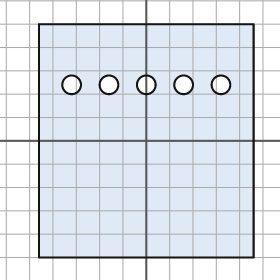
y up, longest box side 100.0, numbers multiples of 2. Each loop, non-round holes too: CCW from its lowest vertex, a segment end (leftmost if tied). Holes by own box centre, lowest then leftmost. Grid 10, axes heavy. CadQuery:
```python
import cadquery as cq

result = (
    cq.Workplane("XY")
    .moveTo(-46.0, -50.0)
    .lineTo(46.0, -50.0)
    .lineTo(46.0, 50.0)
    .lineTo(-46.0, 50.0)
    .close()
    .moveTo(-32.0, 24.0)
    .circle(4.0)
    .moveTo(-16.0, 24.0)
    .circle(4.0)
    .moveTo(0.0, 24.0)
    .circle(4.0)
    .moveTo(16.0, 24.0)
    .circle(4.0)
    .moveTo(32.0, 24.0)
    .circle(4.0)
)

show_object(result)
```